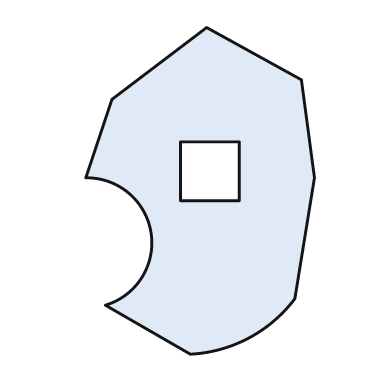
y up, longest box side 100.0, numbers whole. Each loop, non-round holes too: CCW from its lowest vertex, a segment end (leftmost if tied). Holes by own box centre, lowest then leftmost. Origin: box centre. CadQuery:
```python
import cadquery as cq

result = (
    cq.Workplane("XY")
    .moveTo(-3.0, -50.0)
    .threePointArc((15.0, -45.0), (29.0, -33.0))
    .lineTo(35.0, 4.0)
    .lineTo(31.0, 34.0)
    .lineTo(2.0, 50.0)
    .lineTo(-27.0, 28.0)
    .lineTo(-35.0, 4.0)
    .threePointArc((-15.0, -13.0), (-29.0, -35.0))
    .close()
    .moveTo(-6.0, -3.0)
    .lineTo(12.0, -3.0)
    .lineTo(12.0, 15.0)
    .lineTo(-6.0, 15.0)
    .close()
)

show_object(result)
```